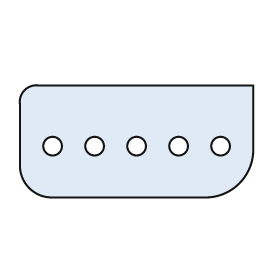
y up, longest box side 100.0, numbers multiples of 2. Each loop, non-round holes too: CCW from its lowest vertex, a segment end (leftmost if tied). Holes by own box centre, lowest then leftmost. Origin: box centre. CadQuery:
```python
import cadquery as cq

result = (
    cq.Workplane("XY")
    .moveTo(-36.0, -24.0)
    .lineTo(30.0, -24.0)
    .threePointArc((44.0, -18.0), (50.0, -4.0))
    .lineTo(50.0, 24.0)
    .lineTo(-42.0, 24.0)
    .threePointArc((-48.0, 22.0), (-50.0, 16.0))
    .lineTo(-50.0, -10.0)
    .threePointArc((-46.0, -20.0), (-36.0, -24.0))
    .close()
    .moveTo(-36.0, -2.0)
    .circle(4.0)
    .moveTo(-18.0, -2.0)
    .circle(4.0)
    .moveTo(0.0, -2.0)
    .circle(4.0)
    .moveTo(18.0, -2.0)
    .circle(4.0)
    .moveTo(36.0, -2.0)
    .circle(4.0)
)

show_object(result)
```